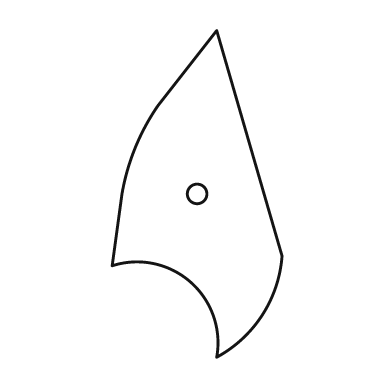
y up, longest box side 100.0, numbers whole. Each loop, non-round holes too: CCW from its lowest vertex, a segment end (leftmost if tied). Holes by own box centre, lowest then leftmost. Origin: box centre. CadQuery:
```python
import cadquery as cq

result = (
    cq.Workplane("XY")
    .moveTo(6.0, -50.0)
    .threePointArc((20.0, -37.0), (26.0, -19.0))
    .lineTo(6.0, 50.0)
    .lineTo(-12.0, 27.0)
    .threePointArc((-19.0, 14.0), (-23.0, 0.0))
    .lineTo(-26.0, -22.0)
    .threePointArc((-2.0, -27.0), (6.0, -50.0))
    .close()
    .moveTo(0.0, 0.0)
    .circle(3.0)
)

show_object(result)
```